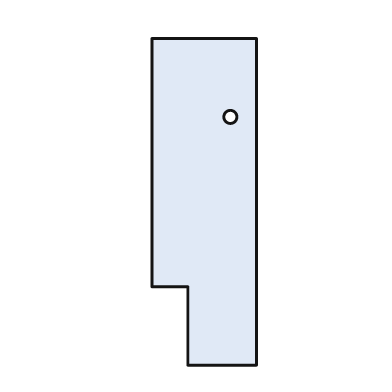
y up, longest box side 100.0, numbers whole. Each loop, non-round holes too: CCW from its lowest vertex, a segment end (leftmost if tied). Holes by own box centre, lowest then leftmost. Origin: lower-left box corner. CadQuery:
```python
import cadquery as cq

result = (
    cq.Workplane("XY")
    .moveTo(11.0, 0.0)
    .lineTo(32.0, 0.0)
    .lineTo(32.0, 100.0)
    .lineTo(0.0, 100.0)
    .lineTo(0.0, 24.0)
    .lineTo(11.0, 24.0)
    .close()
    .moveTo(24.0, 76.0)
    .circle(2.0)
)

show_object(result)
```